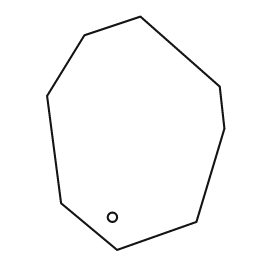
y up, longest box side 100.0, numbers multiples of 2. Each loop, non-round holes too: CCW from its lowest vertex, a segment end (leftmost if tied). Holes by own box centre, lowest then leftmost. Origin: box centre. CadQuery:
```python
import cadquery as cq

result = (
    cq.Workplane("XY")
    .moveTo(-8.0, -50.0)
    .lineTo(26.0, -38.0)
    .lineTo(38.0, 2.0)
    .lineTo(36.0, 20.0)
    .lineTo(2.0, 50.0)
    .lineTo(-22.0, 42.0)
    .lineTo(-38.0, 16.0)
    .lineTo(-32.0, -30.0)
    .close()
    .moveTo(-10.0, -36.0)
    .circle(2.0)
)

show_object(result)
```